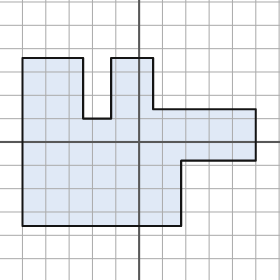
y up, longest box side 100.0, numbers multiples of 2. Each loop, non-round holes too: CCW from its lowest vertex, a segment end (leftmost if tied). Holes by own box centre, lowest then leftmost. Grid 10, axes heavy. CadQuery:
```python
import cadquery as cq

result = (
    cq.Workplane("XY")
    .moveTo(-50.0, -36.0)
    .lineTo(18.0, -36.0)
    .lineTo(18.0, -8.0)
    .lineTo(50.0, -8.0)
    .lineTo(50.0, 14.0)
    .lineTo(6.0, 14.0)
    .lineTo(6.0, 36.0)
    .lineTo(-12.0, 36.0)
    .lineTo(-12.0, 10.0)
    .lineTo(-24.0, 10.0)
    .lineTo(-24.0, 36.0)
    .lineTo(-50.0, 36.0)
    .close()
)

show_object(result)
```